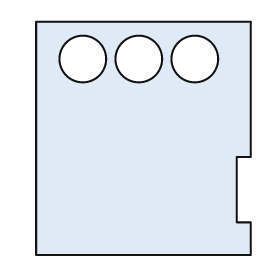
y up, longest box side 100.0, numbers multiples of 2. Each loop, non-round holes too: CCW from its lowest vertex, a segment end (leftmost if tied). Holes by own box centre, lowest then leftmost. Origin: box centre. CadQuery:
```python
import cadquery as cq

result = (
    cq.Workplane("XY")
    .moveTo(-46.0, -50.0)
    .lineTo(46.0, -50.0)
    .lineTo(46.0, -36.0)
    .lineTo(40.0, -36.0)
    .lineTo(40.0, -8.0)
    .lineTo(46.0, -8.0)
    .lineTo(46.0, 50.0)
    .lineTo(-46.0, 50.0)
    .close()
    .moveTo(-26.0, 34.0)
    .circle(10.0)
    .moveTo(-2.0, 34.0)
    .circle(10.0)
    .moveTo(22.0, 34.0)
    .circle(10.0)
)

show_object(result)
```